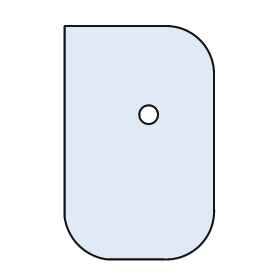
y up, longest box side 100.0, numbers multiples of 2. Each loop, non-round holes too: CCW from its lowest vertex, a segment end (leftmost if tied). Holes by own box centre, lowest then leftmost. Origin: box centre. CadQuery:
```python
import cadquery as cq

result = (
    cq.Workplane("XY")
    .moveTo(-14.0, -50.0)
    .lineTo(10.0, -50.0)
    .threePointArc((26.0, -44.0), (32.0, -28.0))
    .lineTo(32.0, 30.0)
    .threePointArc((26.0, 44.0), (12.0, 50.0))
    .lineTo(-32.0, 50.0)
    .lineTo(-32.0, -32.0)
    .threePointArc((-26.0, -44.0), (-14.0, -50.0))
    .close()
    .moveTo(4.0, 12.0)
    .circle(4.0)
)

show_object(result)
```